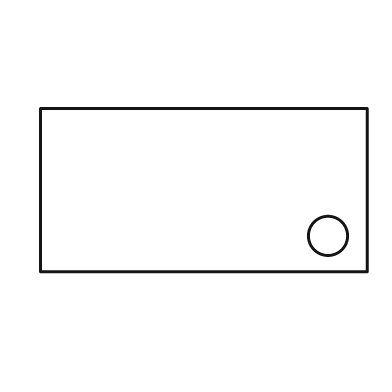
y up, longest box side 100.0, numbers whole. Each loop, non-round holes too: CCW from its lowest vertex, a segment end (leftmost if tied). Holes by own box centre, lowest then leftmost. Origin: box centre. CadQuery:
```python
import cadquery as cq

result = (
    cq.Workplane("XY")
    .moveTo(-50.0, -25.0)
    .lineTo(50.0, -25.0)
    .lineTo(50.0, 25.0)
    .lineTo(-50.0, 25.0)
    .close()
    .moveTo(38.0, -14.0)
    .circle(6.0)
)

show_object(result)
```